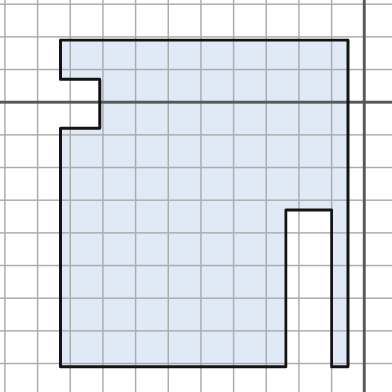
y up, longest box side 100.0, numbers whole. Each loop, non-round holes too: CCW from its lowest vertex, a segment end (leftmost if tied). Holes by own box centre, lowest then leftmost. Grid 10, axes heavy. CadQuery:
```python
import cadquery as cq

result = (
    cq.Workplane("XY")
    .moveTo(-93.0, -81.0)
    .lineTo(-24.0, -81.0)
    .lineTo(-24.0, -33.0)
    .lineTo(-10.0, -33.0)
    .lineTo(-10.0, -81.0)
    .lineTo(-5.0, -81.0)
    .lineTo(-5.0, 19.0)
    .lineTo(-93.0, 19.0)
    .lineTo(-93.0, 7.0)
    .lineTo(-81.0, 7.0)
    .lineTo(-81.0, -8.0)
    .lineTo(-93.0, -8.0)
    .close()
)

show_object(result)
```